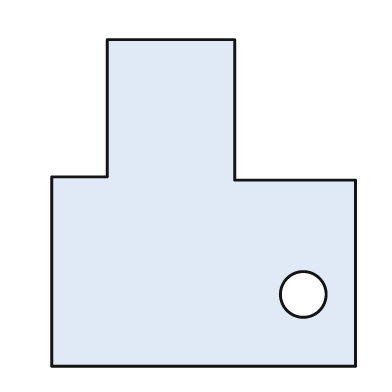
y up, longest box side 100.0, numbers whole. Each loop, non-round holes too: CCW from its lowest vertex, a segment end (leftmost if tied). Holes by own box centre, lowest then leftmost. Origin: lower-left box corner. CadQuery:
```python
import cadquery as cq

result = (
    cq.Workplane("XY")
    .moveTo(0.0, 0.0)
    .lineTo(93.0, 0.0)
    .lineTo(93.0, 57.0)
    .lineTo(56.0, 57.0)
    .lineTo(56.0, 100.0)
    .lineTo(17.0, 100.0)
    .lineTo(17.0, 58.0)
    .lineTo(0.0, 58.0)
    .close()
    .moveTo(77.0, 22.0)
    .circle(7.0)
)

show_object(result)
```